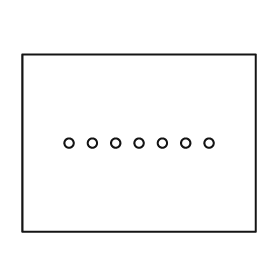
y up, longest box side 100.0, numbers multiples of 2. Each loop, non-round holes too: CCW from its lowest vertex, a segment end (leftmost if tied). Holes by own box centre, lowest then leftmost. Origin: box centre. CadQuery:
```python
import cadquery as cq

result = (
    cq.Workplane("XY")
    .moveTo(-50.0, -38.0)
    .lineTo(50.0, -38.0)
    .lineTo(50.0, 38.0)
    .lineTo(-50.0, 38.0)
    .close()
    .moveTo(-30.0, 0.0)
    .circle(2.0)
    .moveTo(-20.0, 0.0)
    .circle(2.0)
    .moveTo(-10.0, 0.0)
    .circle(2.0)
    .moveTo(0.0, 0.0)
    .circle(2.0)
    .moveTo(10.0, 0.0)
    .circle(2.0)
    .moveTo(20.0, 0.0)
    .circle(2.0)
    .moveTo(30.0, 0.0)
    .circle(2.0)
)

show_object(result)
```